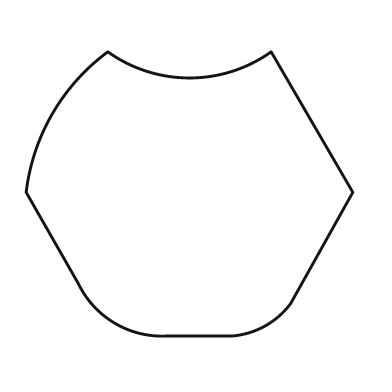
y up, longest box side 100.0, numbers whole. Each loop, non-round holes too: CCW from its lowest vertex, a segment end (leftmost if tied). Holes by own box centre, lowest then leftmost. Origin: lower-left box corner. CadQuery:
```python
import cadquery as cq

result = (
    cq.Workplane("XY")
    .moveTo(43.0, 0.0)
    .lineTo(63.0, 0.0)
    .threePointArc((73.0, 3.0), (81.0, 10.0))
    .lineTo(100.0, 44.0)
    .lineTo(75.0, 87.0)
    .threePointArc((50.0, 79.0), (25.0, 87.0))
    .threePointArc((8.0, 68.0), (0.0, 44.0))
    .lineTo(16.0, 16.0)
    .threePointArc((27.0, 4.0), (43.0, 0.0))
    .close()
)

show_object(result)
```